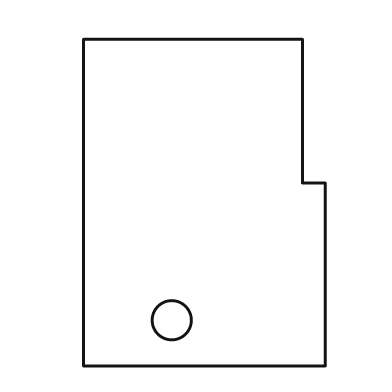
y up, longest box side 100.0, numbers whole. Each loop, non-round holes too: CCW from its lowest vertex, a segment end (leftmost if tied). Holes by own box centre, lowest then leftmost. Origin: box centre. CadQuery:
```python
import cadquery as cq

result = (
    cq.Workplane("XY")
    .moveTo(-37.0, -50.0)
    .lineTo(37.0, -50.0)
    .lineTo(37.0, 6.0)
    .lineTo(30.0, 6.0)
    .lineTo(30.0, 50.0)
    .lineTo(-37.0, 50.0)
    .close()
    .moveTo(-10.0, -36.0)
    .circle(6.0)
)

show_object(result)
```